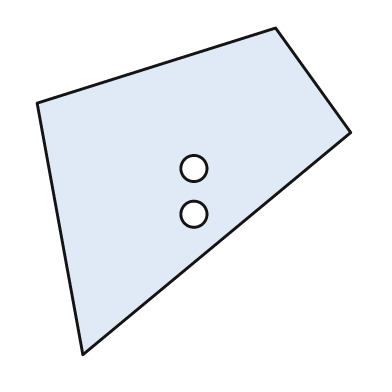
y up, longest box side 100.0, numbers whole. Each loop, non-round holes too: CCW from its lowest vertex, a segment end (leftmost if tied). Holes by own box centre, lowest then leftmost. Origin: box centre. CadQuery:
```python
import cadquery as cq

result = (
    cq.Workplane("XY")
    .moveTo(-34.0, -50.0)
    .lineTo(48.0, 18.0)
    .lineTo(25.0, 50.0)
    .lineTo(-48.0, 27.0)
    .close()
    .moveTo(0.0, -7.0)
    .circle(4.0)
    .moveTo(0.0, 7.0)
    .circle(4.0)
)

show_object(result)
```